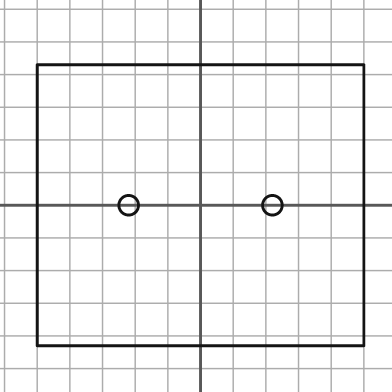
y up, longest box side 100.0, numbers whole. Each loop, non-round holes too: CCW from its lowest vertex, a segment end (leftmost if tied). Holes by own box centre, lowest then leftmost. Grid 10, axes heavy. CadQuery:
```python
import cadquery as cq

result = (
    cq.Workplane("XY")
    .moveTo(-50.0, -43.0)
    .lineTo(50.0, -43.0)
    .lineTo(50.0, 43.0)
    .lineTo(-50.0, 43.0)
    .close()
    .moveTo(-22.0, 0.0)
    .circle(3.0)
    .moveTo(22.0, 0.0)
    .circle(3.0)
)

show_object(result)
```